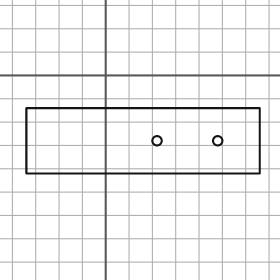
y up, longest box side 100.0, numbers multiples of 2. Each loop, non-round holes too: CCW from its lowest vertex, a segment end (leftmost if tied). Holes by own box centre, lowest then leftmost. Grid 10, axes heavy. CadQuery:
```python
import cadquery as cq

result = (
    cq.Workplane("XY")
    .moveTo(-34.0, -42.0)
    .lineTo(66.0, -42.0)
    .lineTo(66.0, -14.0)
    .lineTo(-34.0, -14.0)
    .close()
    .moveTo(22.0, -28.0)
    .circle(2.0)
    .moveTo(48.0, -28.0)
    .circle(2.0)
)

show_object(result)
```